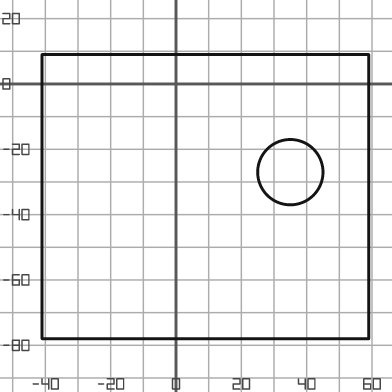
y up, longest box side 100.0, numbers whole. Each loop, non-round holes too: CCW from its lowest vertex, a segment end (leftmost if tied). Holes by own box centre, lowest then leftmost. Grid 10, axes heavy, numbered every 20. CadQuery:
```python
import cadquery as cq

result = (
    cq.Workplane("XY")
    .moveTo(-41.0, -78.0)
    .lineTo(59.0, -78.0)
    .lineTo(59.0, 9.0)
    .lineTo(-41.0, 9.0)
    .close()
    .moveTo(35.0, -27.0)
    .circle(10.0)
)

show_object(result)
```